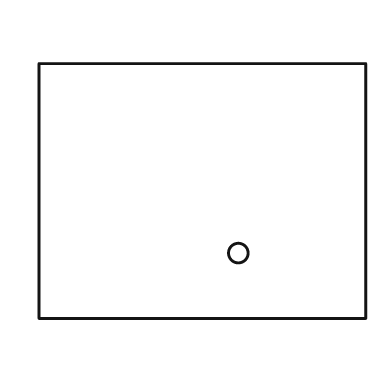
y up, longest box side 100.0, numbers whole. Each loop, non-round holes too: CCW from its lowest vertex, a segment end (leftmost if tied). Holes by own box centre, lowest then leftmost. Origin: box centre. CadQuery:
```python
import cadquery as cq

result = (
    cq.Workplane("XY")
    .moveTo(-50.0, -39.0)
    .lineTo(50.0, -39.0)
    .lineTo(50.0, 39.0)
    .lineTo(-50.0, 39.0)
    .close()
    .moveTo(11.0, -19.0)
    .circle(3.0)
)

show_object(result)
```